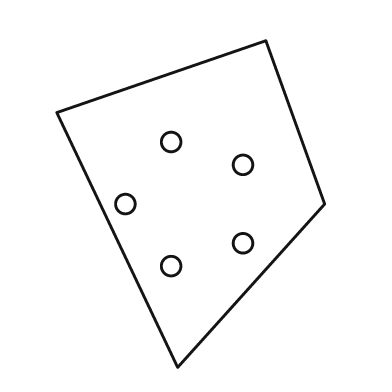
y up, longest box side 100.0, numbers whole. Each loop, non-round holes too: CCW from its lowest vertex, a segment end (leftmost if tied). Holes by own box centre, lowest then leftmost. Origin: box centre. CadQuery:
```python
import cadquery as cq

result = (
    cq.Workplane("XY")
    .moveTo(-4.0, -50.0)
    .lineTo(41.0, 0.0)
    .lineTo(23.0, 50.0)
    .lineTo(-41.0, 28.0)
    .close()
    .moveTo(-6.0, -19.0)
    .circle(3.0)
    .moveTo(16.0, -12.0)
    .circle(3.0)
    .moveTo(-20.0, 0.0)
    .circle(3.0)
    .moveTo(16.0, 12.0)
    .circle(3.0)
    .moveTo(-6.0, 19.0)
    .circle(3.0)
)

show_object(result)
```